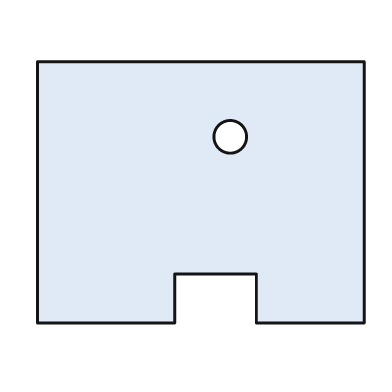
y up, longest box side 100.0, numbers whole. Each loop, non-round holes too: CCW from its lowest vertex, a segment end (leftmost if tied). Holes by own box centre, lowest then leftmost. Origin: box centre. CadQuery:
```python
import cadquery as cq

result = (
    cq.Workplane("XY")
    .moveTo(-50.0, -40.0)
    .lineTo(-8.0, -40.0)
    .lineTo(-8.0, -25.0)
    .lineTo(17.0, -25.0)
    .lineTo(17.0, -40.0)
    .lineTo(50.0, -40.0)
    .lineTo(50.0, 40.0)
    .lineTo(-50.0, 40.0)
    .close()
    .moveTo(9.0, 17.0)
    .circle(5.0)
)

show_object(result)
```